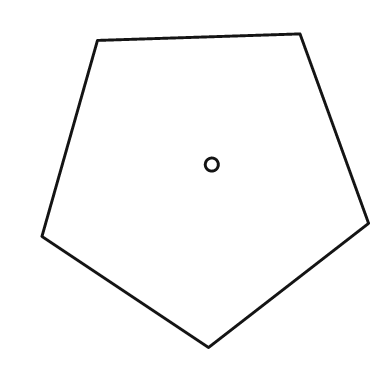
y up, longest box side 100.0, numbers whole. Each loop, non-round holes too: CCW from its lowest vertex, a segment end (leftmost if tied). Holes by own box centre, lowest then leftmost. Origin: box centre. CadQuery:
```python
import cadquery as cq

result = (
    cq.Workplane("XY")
    .moveTo(1.0, -48.0)
    .lineTo(50.0, -10.0)
    .lineTo(29.0, 48.0)
    .lineTo(-33.0, 46.0)
    .lineTo(-50.0, -14.0)
    .close()
    .moveTo(2.0, 8.0)
    .circle(2.0)
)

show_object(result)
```